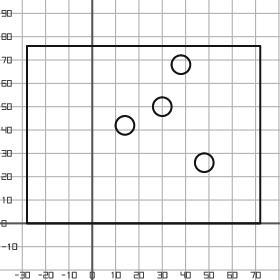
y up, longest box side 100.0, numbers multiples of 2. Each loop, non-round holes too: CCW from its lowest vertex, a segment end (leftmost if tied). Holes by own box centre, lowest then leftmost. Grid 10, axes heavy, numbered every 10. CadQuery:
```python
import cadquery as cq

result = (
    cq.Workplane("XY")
    .moveTo(-28.0, 0.0)
    .lineTo(72.0, 0.0)
    .lineTo(72.0, 76.0)
    .lineTo(-28.0, 76.0)
    .close()
    .moveTo(48.0, 26.0)
    .circle(4.0)
    .moveTo(14.0, 42.0)
    .circle(4.0)
    .moveTo(30.0, 50.0)
    .circle(4.0)
    .moveTo(38.0, 68.0)
    .circle(4.0)
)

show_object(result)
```